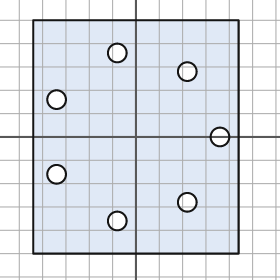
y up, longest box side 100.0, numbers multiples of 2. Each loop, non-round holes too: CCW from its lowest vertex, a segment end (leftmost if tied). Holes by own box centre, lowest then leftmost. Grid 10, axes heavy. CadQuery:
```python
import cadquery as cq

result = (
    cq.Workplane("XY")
    .moveTo(-44.0, -50.0)
    .lineTo(44.0, -50.0)
    .lineTo(44.0, 50.0)
    .lineTo(-44.0, 50.0)
    .close()
    .moveTo(-8.0, -36.0)
    .circle(4.0)
    .moveTo(22.0, -28.0)
    .circle(4.0)
    .moveTo(-34.0, -16.0)
    .circle(4.0)
    .moveTo(36.0, 0.0)
    .circle(4.0)
    .moveTo(-34.0, 16.0)
    .circle(4.0)
    .moveTo(22.0, 28.0)
    .circle(4.0)
    .moveTo(-8.0, 36.0)
    .circle(4.0)
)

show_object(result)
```